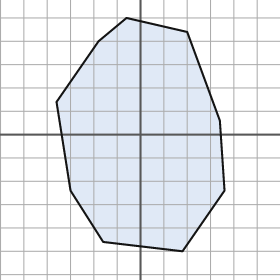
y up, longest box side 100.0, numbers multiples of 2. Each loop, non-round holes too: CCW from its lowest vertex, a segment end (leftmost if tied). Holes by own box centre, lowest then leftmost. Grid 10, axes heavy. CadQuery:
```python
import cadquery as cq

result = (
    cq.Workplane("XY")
    .moveTo(18.0, -50.0)
    .lineTo(36.0, -24.0)
    .lineTo(34.0, 6.0)
    .lineTo(20.0, 44.0)
    .lineTo(-6.0, 50.0)
    .lineTo(-18.0, 40.0)
    .lineTo(-36.0, 14.0)
    .lineTo(-30.0, -24.0)
    .lineTo(-16.0, -46.0)
    .close()
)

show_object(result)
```